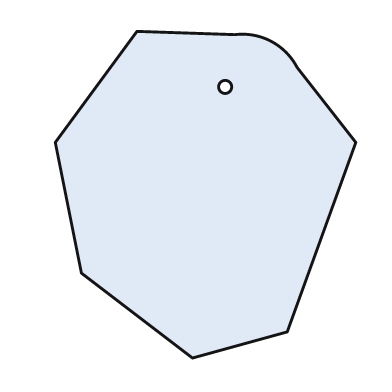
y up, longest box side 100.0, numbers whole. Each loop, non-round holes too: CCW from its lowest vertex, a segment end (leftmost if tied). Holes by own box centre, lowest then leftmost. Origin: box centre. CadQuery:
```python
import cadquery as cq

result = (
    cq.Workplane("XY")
    .moveTo(-4.0, -50.0)
    .lineTo(25.0, -42.0)
    .lineTo(46.0, 16.0)
    .lineTo(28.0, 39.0)
    .threePointArc((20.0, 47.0), (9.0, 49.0))
    .lineTo(-21.0, 50.0)
    .lineTo(-46.0, 16.0)
    .lineTo(-38.0, -24.0)
    .close()
    .moveTo(6.0, 33.0)
    .circle(2.0)
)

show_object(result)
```